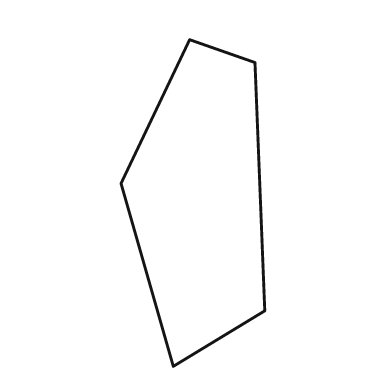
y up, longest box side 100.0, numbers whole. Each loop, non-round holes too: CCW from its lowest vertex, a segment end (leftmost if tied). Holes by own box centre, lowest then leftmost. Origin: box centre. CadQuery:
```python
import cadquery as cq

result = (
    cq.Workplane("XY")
    .moveTo(-6.0, -50.0)
    .lineTo(22.0, -33.0)
    .lineTo(19.0, 43.0)
    .lineTo(-1.0, 50.0)
    .lineTo(-22.0, 6.0)
    .close()
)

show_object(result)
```